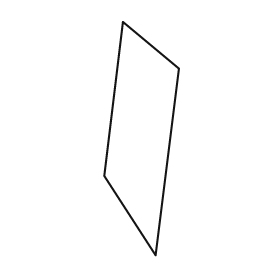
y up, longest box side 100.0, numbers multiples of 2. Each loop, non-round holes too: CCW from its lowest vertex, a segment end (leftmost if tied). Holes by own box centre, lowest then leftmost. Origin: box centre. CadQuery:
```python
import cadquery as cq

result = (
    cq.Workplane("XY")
    .moveTo(6.0, -50.0)
    .lineTo(16.0, 30.0)
    .lineTo(-8.0, 50.0)
    .lineTo(-16.0, -16.0)
    .close()
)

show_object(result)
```